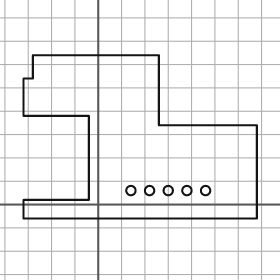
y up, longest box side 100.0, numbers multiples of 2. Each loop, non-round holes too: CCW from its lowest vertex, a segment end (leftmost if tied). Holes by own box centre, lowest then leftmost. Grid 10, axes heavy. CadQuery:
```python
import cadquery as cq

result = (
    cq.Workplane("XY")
    .moveTo(-32.0, -6.0)
    .lineTo(68.0, -6.0)
    .lineTo(68.0, 34.0)
    .lineTo(26.0, 34.0)
    .lineTo(26.0, 64.0)
    .lineTo(-28.0, 64.0)
    .lineTo(-28.0, 54.0)
    .lineTo(-32.0, 54.0)
    .lineTo(-32.0, 38.0)
    .lineTo(-4.0, 38.0)
    .lineTo(-4.0, 2.0)
    .lineTo(-32.0, 2.0)
    .close()
    .moveTo(14.0, 6.0)
    .circle(2.0)
    .moveTo(22.0, 6.0)
    .circle(2.0)
    .moveTo(30.0, 6.0)
    .circle(2.0)
    .moveTo(38.0, 6.0)
    .circle(2.0)
    .moveTo(46.0, 6.0)
    .circle(2.0)
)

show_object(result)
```